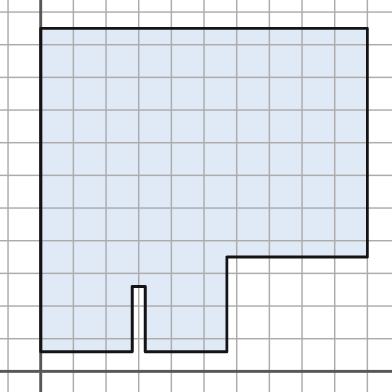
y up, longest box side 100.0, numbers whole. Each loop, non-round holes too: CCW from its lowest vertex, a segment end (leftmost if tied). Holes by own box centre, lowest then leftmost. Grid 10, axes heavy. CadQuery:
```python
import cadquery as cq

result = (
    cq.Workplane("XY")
    .moveTo(0.0, 6.0)
    .lineTo(28.0, 6.0)
    .lineTo(28.0, 26.0)
    .lineTo(32.0, 26.0)
    .lineTo(32.0, 6.0)
    .lineTo(57.0, 6.0)
    .lineTo(57.0, 35.0)
    .lineTo(100.0, 35.0)
    .lineTo(100.0, 105.0)
    .lineTo(0.0, 105.0)
    .close()
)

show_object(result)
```